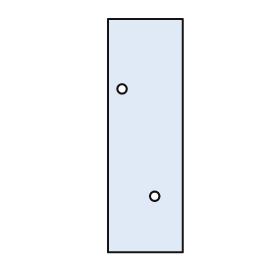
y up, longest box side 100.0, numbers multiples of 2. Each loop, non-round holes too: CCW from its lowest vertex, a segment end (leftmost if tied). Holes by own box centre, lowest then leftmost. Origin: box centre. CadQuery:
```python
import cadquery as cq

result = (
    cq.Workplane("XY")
    .moveTo(-16.0, -50.0)
    .lineTo(16.0, -50.0)
    .lineTo(16.0, 50.0)
    .lineTo(-16.0, 50.0)
    .close()
    .moveTo(4.0, -26.0)
    .circle(2.0)
    .moveTo(-10.0, 20.0)
    .circle(2.0)
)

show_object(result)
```